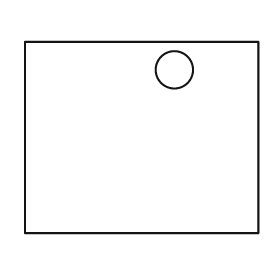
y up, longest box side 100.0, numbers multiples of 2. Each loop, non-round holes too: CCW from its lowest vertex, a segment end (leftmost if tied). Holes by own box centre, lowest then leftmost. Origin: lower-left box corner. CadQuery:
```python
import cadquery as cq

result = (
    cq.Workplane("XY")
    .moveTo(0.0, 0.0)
    .lineTo(100.0, 0.0)
    .lineTo(100.0, 82.0)
    .lineTo(0.0, 82.0)
    .close()
    .moveTo(64.0, 70.0)
    .circle(8.0)
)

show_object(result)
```